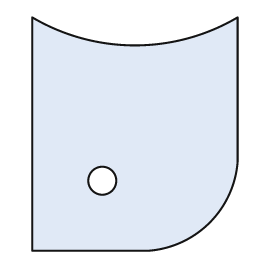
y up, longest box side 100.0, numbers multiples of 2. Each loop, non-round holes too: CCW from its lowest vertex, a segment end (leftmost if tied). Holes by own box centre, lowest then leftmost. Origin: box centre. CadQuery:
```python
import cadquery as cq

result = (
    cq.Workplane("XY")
    .moveTo(-44.0, -50.0)
    .lineTo(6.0, -50.0)
    .threePointArc((32.0, -38.0), (44.0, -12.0))
    .lineTo(44.0, 50.0)
    .threePointArc((0.0, 38.0), (-44.0, 50.0))
    .close()
    .moveTo(-14.0, -20.0)
    .circle(6.0)
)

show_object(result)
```